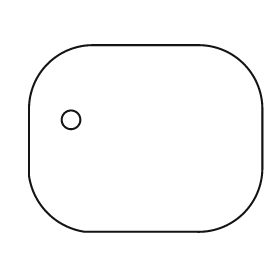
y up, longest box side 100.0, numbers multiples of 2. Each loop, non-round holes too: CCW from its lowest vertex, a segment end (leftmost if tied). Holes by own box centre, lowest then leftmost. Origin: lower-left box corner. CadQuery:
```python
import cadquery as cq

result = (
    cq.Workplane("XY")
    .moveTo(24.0, 0.0)
    .lineTo(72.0, 0.0)
    .threePointArc((92.0, 8.0), (100.0, 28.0))
    .lineTo(100.0, 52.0)
    .threePointArc((92.0, 72.0), (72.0, 80.0))
    .lineTo(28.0, 80.0)
    .threePointArc((8.0, 72.0), (0.0, 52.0))
    .lineTo(0.0, 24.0)
    .threePointArc((8.0, 8.0), (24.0, 0.0))
    .close()
    .moveTo(18.0, 48.0)
    .circle(4.0)
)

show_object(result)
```